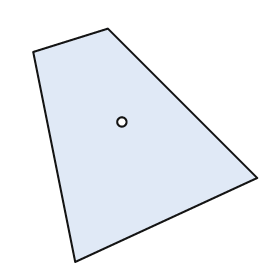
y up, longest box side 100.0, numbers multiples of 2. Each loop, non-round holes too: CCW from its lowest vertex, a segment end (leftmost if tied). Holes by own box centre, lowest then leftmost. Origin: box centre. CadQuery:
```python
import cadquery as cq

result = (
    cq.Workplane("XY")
    .moveTo(-30.0, -50.0)
    .lineTo(48.0, -14.0)
    .lineTo(-16.0, 50.0)
    .lineTo(-48.0, 40.0)
    .close()
    .moveTo(-10.0, 10.0)
    .circle(2.0)
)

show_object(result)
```